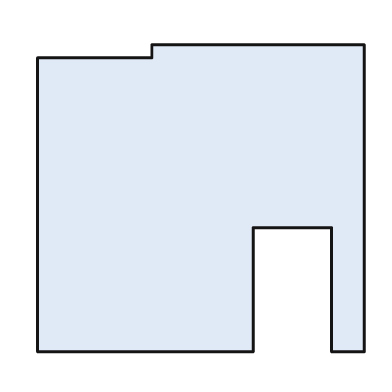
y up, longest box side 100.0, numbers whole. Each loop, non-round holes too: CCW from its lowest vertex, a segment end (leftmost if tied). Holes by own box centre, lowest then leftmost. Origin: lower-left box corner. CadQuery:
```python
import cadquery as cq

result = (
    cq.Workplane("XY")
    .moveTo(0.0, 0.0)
    .lineTo(66.0, 0.0)
    .lineTo(66.0, 38.0)
    .lineTo(90.0, 38.0)
    .lineTo(90.0, 0.0)
    .lineTo(100.0, 0.0)
    .lineTo(100.0, 94.0)
    .lineTo(35.0, 94.0)
    .lineTo(35.0, 90.0)
    .lineTo(0.0, 90.0)
    .close()
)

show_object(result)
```